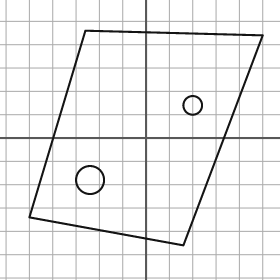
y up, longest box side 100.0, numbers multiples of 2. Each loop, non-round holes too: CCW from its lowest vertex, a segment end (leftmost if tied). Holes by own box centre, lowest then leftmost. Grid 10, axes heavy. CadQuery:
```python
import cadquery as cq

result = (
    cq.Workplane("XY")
    .moveTo(16.0, -46.0)
    .lineTo(50.0, 44.0)
    .lineTo(-26.0, 46.0)
    .lineTo(-50.0, -34.0)
    .close()
    .moveTo(-24.0, -18.0)
    .circle(6.0)
    .moveTo(20.0, 14.0)
    .circle(4.0)
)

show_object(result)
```